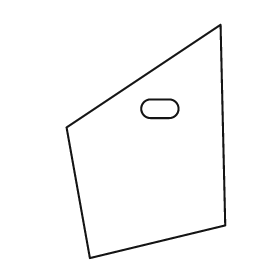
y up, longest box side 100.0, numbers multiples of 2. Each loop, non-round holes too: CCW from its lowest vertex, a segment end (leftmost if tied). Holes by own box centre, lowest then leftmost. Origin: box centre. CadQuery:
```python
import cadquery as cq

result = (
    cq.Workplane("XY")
    .moveTo(-24.0, -50.0)
    .lineTo(34.0, -36.0)
    .lineTo(32.0, 50.0)
    .lineTo(-34.0, 6.0)
    .close()
    .moveTo(2.0, 10.0)
    .lineTo(10.0, 10.0)
    .threePointArc((14.0, 14.0), (10.0, 18.0))
    .lineTo(2.0, 18.0)
    .threePointArc((-2.0, 14.0), (2.0, 10.0))
    .close()
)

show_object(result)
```